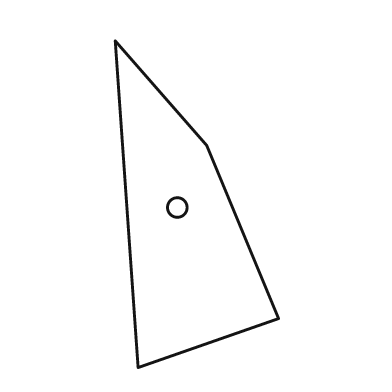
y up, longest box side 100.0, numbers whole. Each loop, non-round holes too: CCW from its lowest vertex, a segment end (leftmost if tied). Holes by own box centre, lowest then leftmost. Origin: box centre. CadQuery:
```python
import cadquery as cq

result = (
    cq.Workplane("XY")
    .moveTo(-18.0, -50.0)
    .lineTo(25.0, -35.0)
    .lineTo(3.0, 18.0)
    .lineTo(-25.0, 50.0)
    .close()
    .moveTo(-6.0, -1.0)
    .circle(3.0)
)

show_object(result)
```